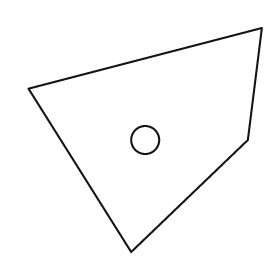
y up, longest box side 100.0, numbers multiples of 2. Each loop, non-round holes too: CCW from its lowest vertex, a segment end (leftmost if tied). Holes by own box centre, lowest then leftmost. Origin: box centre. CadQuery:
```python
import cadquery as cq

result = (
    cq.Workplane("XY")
    .moveTo(-6.0, -48.0)
    .lineTo(44.0, 0.0)
    .lineTo(50.0, 48.0)
    .lineTo(-50.0, 22.0)
    .close()
    .moveTo(0.0, 0.0)
    .circle(6.0)
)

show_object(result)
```